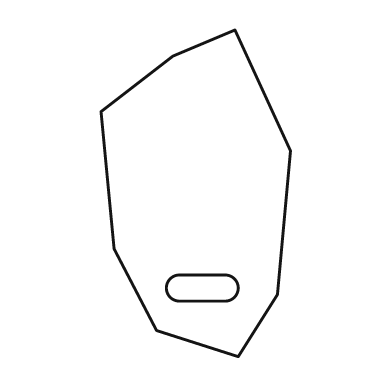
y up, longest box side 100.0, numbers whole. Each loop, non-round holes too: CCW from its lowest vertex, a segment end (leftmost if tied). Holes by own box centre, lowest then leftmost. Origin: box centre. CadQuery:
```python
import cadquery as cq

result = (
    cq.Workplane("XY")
    .moveTo(13.0, -50.0)
    .lineTo(25.0, -31.0)
    .lineTo(29.0, 13.0)
    .lineTo(12.0, 50.0)
    .lineTo(-7.0, 42.0)
    .lineTo(-29.0, 25.0)
    .lineTo(-25.0, -17.0)
    .lineTo(-12.0, -42.0)
    .close()
    .moveTo(-5.0, -33.0)
    .lineTo(9.0, -33.0)
    .threePointArc((13.0, -29.0), (9.0, -25.0))
    .lineTo(-5.0, -25.0)
    .threePointArc((-9.0, -29.0), (-5.0, -33.0))
    .close()
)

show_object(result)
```